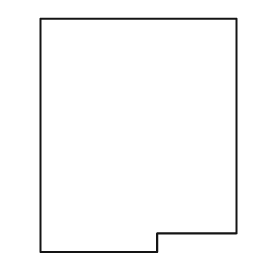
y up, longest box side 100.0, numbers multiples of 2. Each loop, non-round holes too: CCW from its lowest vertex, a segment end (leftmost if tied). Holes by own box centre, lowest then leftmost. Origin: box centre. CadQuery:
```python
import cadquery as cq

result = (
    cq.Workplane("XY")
    .moveTo(-42.0, -50.0)
    .lineTo(8.0, -50.0)
    .lineTo(8.0, -42.0)
    .lineTo(42.0, -42.0)
    .lineTo(42.0, 50.0)
    .lineTo(-42.0, 50.0)
    .close()
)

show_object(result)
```